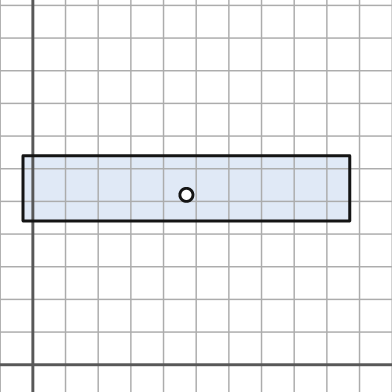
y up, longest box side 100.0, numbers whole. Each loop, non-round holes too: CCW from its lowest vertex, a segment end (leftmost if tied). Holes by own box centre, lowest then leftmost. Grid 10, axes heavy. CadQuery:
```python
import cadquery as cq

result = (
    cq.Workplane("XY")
    .moveTo(-3.0, 44.0)
    .lineTo(97.0, 44.0)
    .lineTo(97.0, 64.0)
    .lineTo(-3.0, 64.0)
    .close()
    .moveTo(47.0, 52.0)
    .circle(2.0)
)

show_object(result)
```